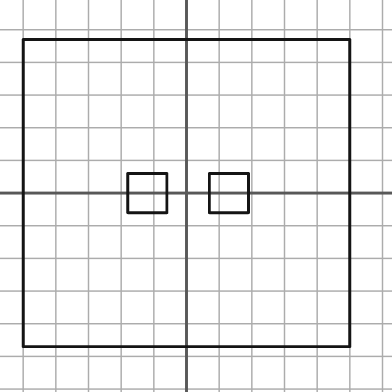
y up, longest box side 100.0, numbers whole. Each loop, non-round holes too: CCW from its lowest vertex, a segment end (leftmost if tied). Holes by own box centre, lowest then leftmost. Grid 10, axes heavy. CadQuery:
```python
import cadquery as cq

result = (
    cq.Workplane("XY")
    .moveTo(-50.0, -47.0)
    .lineTo(50.0, -47.0)
    .lineTo(50.0, 47.0)
    .lineTo(-50.0, 47.0)
    .close()
    .moveTo(-18.0, -6.0)
    .lineTo(-6.0, -6.0)
    .lineTo(-6.0, 6.0)
    .lineTo(-18.0, 6.0)
    .close()
    .moveTo(7.0, -6.0)
    .lineTo(19.0, -6.0)
    .lineTo(19.0, 6.0)
    .lineTo(7.0, 6.0)
    .close()
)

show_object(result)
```